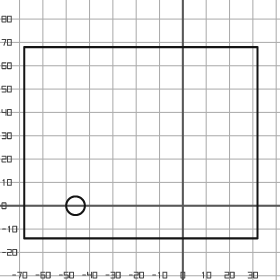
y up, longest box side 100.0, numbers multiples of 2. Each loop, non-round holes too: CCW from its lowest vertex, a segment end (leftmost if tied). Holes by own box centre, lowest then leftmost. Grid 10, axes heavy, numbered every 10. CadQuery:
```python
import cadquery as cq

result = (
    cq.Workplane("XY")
    .moveTo(-68.0, -14.0)
    .lineTo(32.0, -14.0)
    .lineTo(32.0, 68.0)
    .lineTo(-68.0, 68.0)
    .close()
    .moveTo(-46.0, 0.0)
    .circle(4.0)
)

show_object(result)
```